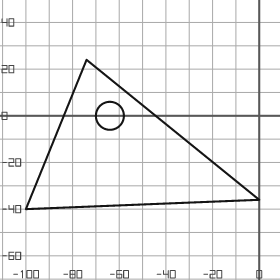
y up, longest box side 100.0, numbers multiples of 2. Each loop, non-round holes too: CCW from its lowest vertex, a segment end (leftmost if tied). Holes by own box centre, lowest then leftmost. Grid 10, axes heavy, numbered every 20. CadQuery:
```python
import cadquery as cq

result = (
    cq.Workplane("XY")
    .moveTo(-100.0, -40.0)
    .lineTo(0.0, -36.0)
    .lineTo(-74.0, 24.0)
    .close()
    .moveTo(-64.0, 0.0)
    .circle(6.0)
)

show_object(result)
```